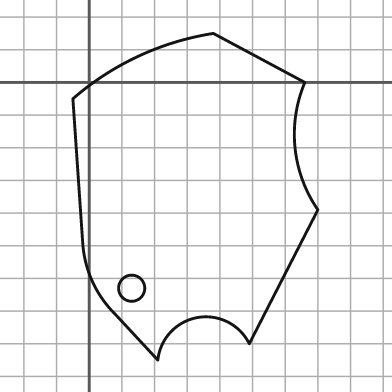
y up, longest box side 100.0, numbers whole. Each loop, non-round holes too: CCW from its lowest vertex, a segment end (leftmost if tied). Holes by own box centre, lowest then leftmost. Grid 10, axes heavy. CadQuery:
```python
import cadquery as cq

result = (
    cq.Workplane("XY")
    .moveTo(21.0, -85.0)
    .threePointArc((33.0, -72.0), (49.0, -80.0))
    .lineTo(70.0, -39.0)
    .threePointArc((63.0, -20.0), (66.0, 0.0))
    .lineTo(38.0, 15.0)
    .threePointArc((15.0, 8.0), (-5.0, -5.0))
    .lineTo(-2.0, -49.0)
    .threePointArc((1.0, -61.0), (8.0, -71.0))
    .close()
    .moveTo(13.0, -63.0)
    .circle(4.0)
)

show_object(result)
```